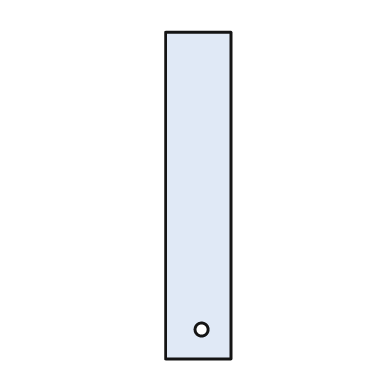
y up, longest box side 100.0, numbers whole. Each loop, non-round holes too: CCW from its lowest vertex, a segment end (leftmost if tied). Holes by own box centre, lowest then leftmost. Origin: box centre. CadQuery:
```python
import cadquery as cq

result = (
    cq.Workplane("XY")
    .moveTo(-10.0, -50.0)
    .lineTo(10.0, -50.0)
    .lineTo(10.0, 50.0)
    .lineTo(-10.0, 50.0)
    .close()
    .moveTo(1.0, -41.0)
    .circle(2.0)
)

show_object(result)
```